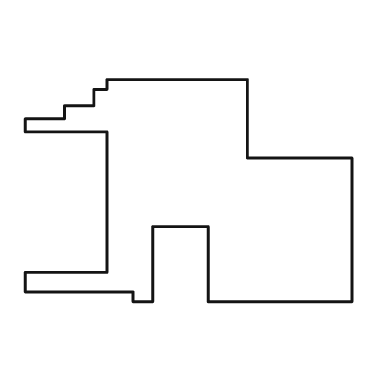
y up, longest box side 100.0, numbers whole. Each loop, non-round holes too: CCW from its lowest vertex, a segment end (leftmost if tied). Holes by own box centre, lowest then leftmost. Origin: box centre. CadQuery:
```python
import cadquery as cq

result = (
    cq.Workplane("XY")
    .moveTo(-17.0, -34.0)
    .lineTo(-11.0, -34.0)
    .lineTo(-11.0, -11.0)
    .lineTo(6.0, -11.0)
    .lineTo(6.0, -34.0)
    .lineTo(50.0, -34.0)
    .lineTo(50.0, 10.0)
    .lineTo(18.0, 10.0)
    .lineTo(18.0, 34.0)
    .lineTo(-25.0, 34.0)
    .lineTo(-25.0, 31.0)
    .lineTo(-29.0, 31.0)
    .lineTo(-29.0, 26.0)
    .lineTo(-38.0, 26.0)
    .lineTo(-38.0, 22.0)
    .lineTo(-50.0, 22.0)
    .lineTo(-50.0, 18.0)
    .lineTo(-25.0, 18.0)
    .lineTo(-25.0, -25.0)
    .lineTo(-50.0, -25.0)
    .lineTo(-50.0, -31.0)
    .lineTo(-17.0, -31.0)
    .close()
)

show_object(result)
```